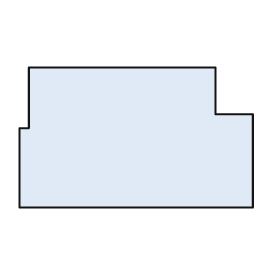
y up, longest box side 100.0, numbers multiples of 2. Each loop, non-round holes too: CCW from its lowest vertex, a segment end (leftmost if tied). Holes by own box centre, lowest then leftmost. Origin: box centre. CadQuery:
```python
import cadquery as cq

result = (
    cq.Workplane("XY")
    .moveTo(-50.0, -30.0)
    .lineTo(50.0, -30.0)
    .lineTo(50.0, 10.0)
    .lineTo(34.0, 10.0)
    .lineTo(34.0, 30.0)
    .lineTo(-46.0, 30.0)
    .lineTo(-46.0, 4.0)
    .lineTo(-50.0, 4.0)
    .close()
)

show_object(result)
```